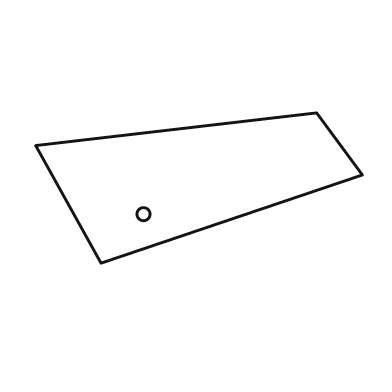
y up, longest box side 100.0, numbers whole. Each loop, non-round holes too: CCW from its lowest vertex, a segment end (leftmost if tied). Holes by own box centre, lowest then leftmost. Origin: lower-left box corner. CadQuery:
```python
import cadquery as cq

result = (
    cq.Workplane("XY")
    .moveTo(20.0, 0.0)
    .lineTo(100.0, 27.0)
    .lineTo(86.0, 46.0)
    .lineTo(0.0, 36.0)
    .close()
    .moveTo(33.0, 15.0)
    .circle(2.0)
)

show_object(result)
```